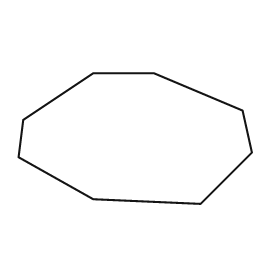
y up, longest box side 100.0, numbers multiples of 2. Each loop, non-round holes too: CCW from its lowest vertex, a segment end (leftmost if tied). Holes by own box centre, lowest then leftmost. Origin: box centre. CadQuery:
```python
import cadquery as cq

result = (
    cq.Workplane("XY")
    .moveTo(28.0, -28.0)
    .lineTo(50.0, -6.0)
    .lineTo(46.0, 12.0)
    .lineTo(8.0, 28.0)
    .lineTo(-18.0, 28.0)
    .lineTo(-48.0, 8.0)
    .lineTo(-50.0, -8.0)
    .lineTo(-18.0, -26.0)
    .close()
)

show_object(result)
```